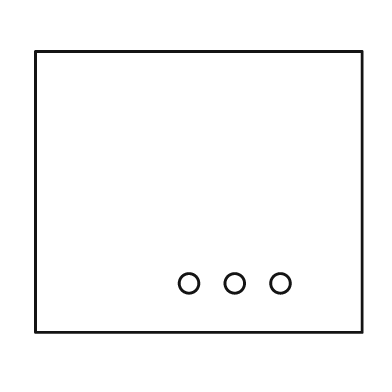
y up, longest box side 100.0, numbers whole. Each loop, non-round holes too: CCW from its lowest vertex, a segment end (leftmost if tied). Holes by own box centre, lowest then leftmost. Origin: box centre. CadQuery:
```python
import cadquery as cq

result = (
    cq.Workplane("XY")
    .moveTo(-50.0, -43.0)
    .lineTo(50.0, -43.0)
    .lineTo(50.0, 43.0)
    .lineTo(-50.0, 43.0)
    .close()
    .moveTo(-3.0, -28.0)
    .circle(3.0)
    .moveTo(11.0, -28.0)
    .circle(3.0)
    .moveTo(25.0, -28.0)
    .circle(3.0)
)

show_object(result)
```